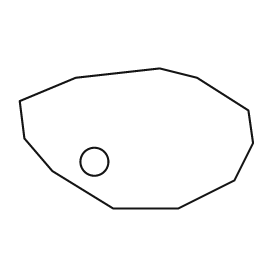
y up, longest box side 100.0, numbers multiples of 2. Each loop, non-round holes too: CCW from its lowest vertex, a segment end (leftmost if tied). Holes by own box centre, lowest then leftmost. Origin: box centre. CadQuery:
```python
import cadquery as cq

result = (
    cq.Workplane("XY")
    .moveTo(-10.0, -30.0)
    .lineTo(18.0, -30.0)
    .lineTo(42.0, -18.0)
    .lineTo(50.0, -2.0)
    .lineTo(48.0, 12.0)
    .lineTo(26.0, 26.0)
    .lineTo(10.0, 30.0)
    .lineTo(-26.0, 26.0)
    .lineTo(-50.0, 16.0)
    .lineTo(-48.0, 0.0)
    .lineTo(-36.0, -14.0)
    .close()
    .moveTo(-18.0, -10.0)
    .circle(6.0)
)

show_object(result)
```